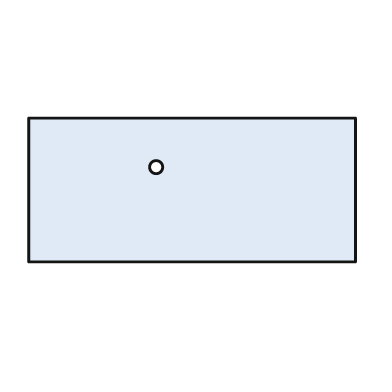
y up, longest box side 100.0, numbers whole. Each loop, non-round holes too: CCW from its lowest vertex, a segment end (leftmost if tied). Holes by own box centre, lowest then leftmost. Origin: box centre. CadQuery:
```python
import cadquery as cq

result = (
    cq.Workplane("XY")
    .moveTo(-50.0, -22.0)
    .lineTo(50.0, -22.0)
    .lineTo(50.0, 22.0)
    .lineTo(-50.0, 22.0)
    .close()
    .moveTo(-11.0, 7.0)
    .circle(2.0)
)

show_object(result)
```